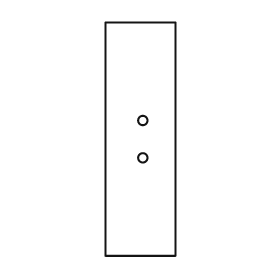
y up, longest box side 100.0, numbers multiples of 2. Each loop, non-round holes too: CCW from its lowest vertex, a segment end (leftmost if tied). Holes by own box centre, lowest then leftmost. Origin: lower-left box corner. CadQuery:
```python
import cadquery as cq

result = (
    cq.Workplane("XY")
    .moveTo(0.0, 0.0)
    .lineTo(30.0, 0.0)
    .lineTo(30.0, 100.0)
    .lineTo(0.0, 100.0)
    .close()
    .moveTo(16.0, 42.0)
    .circle(2.0)
    .moveTo(16.0, 58.0)
    .circle(2.0)
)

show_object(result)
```